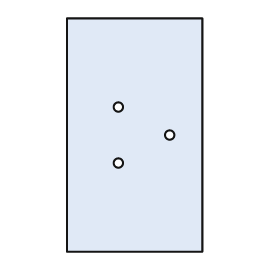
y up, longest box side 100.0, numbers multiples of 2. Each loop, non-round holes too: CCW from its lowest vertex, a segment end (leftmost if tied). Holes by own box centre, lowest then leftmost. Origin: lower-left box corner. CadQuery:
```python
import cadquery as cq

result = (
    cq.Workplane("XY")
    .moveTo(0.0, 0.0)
    .lineTo(58.0, 0.0)
    .lineTo(58.0, 100.0)
    .lineTo(0.0, 100.0)
    .close()
    .moveTo(22.0, 38.0)
    .circle(2.0)
    .moveTo(44.0, 50.0)
    .circle(2.0)
    .moveTo(22.0, 62.0)
    .circle(2.0)
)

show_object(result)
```